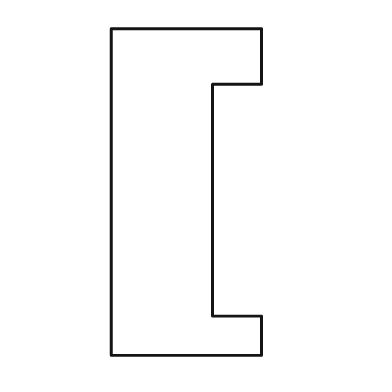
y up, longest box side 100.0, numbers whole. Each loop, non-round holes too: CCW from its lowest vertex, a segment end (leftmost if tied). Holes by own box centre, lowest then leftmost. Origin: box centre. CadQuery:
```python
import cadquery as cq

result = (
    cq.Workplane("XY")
    .moveTo(-23.0, -50.0)
    .lineTo(23.0, -50.0)
    .lineTo(23.0, -38.0)
    .lineTo(8.0, -38.0)
    .lineTo(8.0, 33.0)
    .lineTo(23.0, 33.0)
    .lineTo(23.0, 50.0)
    .lineTo(-23.0, 50.0)
    .close()
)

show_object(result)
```